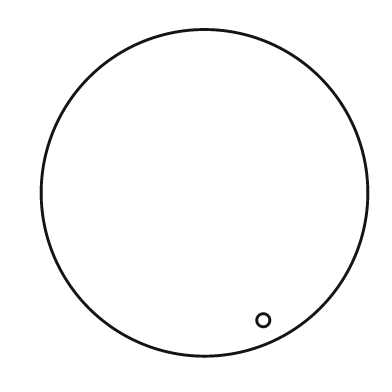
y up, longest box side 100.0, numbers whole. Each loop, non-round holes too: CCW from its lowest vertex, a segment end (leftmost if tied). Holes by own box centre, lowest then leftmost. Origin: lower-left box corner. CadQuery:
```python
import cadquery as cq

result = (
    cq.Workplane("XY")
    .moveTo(50.0, 50.0)
    .circle(50.0)
    .moveTo(68.0, 11.0)
    .circle(2.0)
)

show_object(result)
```